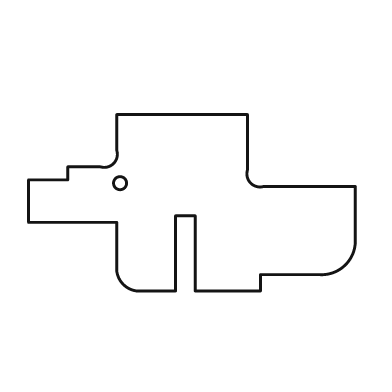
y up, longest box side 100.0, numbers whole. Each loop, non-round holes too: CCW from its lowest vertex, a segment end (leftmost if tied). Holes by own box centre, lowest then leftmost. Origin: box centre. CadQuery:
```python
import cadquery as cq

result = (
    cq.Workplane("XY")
    .moveTo(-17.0, -27.0)
    .lineTo(-5.0, -27.0)
    .lineTo(-5.0, -4.0)
    .lineTo(1.0, -4.0)
    .lineTo(1.0, -27.0)
    .lineTo(21.0, -27.0)
    .lineTo(21.0, -22.0)
    .lineTo(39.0, -22.0)
    .threePointArc((47.0, -19.0), (50.0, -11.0))
    .lineTo(50.0, 5.0)
    .lineTo(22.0, 5.0)
    .threePointArc((18.0, 6.0), (17.0, 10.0))
    .lineTo(17.0, 27.0)
    .lineTo(-23.0, 27.0)
    .lineTo(-23.0, 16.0)
    .threePointArc((-24.0, 12.0), (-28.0, 11.0))
    .lineTo(-38.0, 11.0)
    .lineTo(-38.0, 7.0)
    .lineTo(-50.0, 7.0)
    .lineTo(-50.0, -6.0)
    .lineTo(-23.0, -6.0)
    .lineTo(-23.0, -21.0)
    .threePointArc((-21.0, -25.0), (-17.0, -27.0))
    .close()
    .moveTo(-22.0, 6.0)
    .circle(2.0)
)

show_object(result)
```